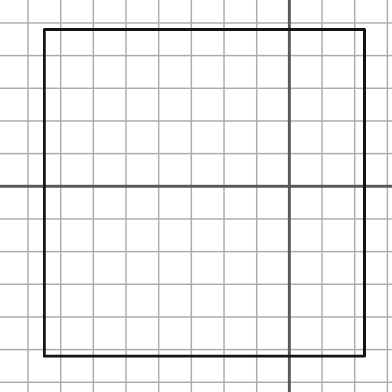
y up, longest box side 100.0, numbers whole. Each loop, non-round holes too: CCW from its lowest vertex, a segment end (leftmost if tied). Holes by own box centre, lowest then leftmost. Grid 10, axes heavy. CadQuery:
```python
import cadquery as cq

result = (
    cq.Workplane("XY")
    .moveTo(-75.0, -52.0)
    .lineTo(23.0, -52.0)
    .lineTo(23.0, 48.0)
    .lineTo(-75.0, 48.0)
    .close()
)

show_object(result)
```